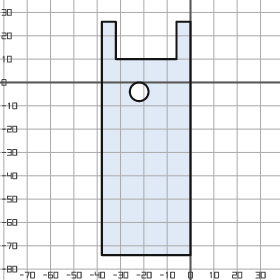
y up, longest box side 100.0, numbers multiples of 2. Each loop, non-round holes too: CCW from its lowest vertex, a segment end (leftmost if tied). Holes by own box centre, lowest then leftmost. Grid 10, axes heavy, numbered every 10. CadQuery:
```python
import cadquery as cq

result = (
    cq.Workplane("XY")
    .moveTo(-38.0, -74.0)
    .lineTo(0.0, -74.0)
    .lineTo(0.0, 26.0)
    .lineTo(-6.0, 26.0)
    .lineTo(-6.0, 10.0)
    .lineTo(-32.0, 10.0)
    .lineTo(-32.0, 26.0)
    .lineTo(-38.0, 26.0)
    .close()
    .moveTo(-22.0, -4.0)
    .circle(4.0)
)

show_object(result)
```